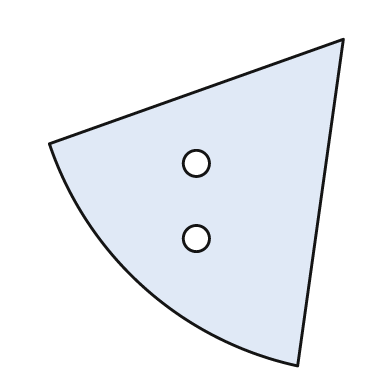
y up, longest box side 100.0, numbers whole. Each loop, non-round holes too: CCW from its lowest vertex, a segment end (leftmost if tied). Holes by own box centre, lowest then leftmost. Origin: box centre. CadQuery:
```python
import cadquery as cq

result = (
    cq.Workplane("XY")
    .moveTo(31.0, -50.0)
    .lineTo(45.0, 50.0)
    .lineTo(-45.0, 18.0)
    .threePointArc((-16.0, -26.0), (31.0, -50.0))
    .close()
    .moveTo(0.0, -11.0)
    .circle(4.0)
    .moveTo(0.0, 12.0)
    .circle(4.0)
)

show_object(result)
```